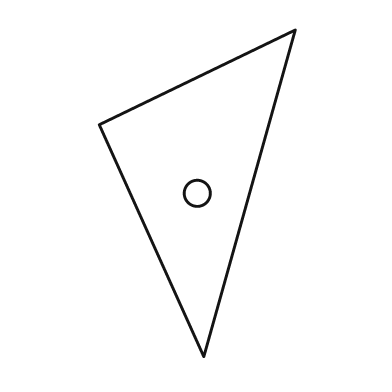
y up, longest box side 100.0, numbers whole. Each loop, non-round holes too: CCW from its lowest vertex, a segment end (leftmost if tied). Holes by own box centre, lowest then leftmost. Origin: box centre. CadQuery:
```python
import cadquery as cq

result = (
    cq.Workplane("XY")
    .moveTo(2.0, -50.0)
    .lineTo(30.0, 50.0)
    .lineTo(-30.0, 21.0)
    .close()
    .moveTo(0.0, 0.0)
    .circle(4.0)
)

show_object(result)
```